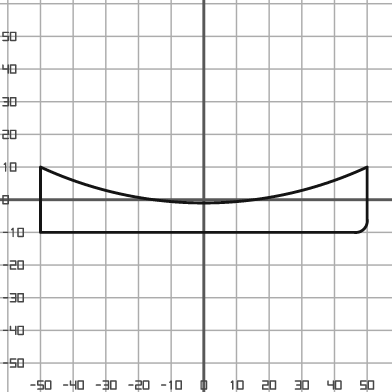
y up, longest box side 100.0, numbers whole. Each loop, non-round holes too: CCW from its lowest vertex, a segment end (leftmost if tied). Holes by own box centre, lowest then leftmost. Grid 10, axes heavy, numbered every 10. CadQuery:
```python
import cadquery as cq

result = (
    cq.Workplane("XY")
    .moveTo(-50.0, -10.0)
    .lineTo(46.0, -10.0)
    .threePointArc((49.0, -9.0), (50.0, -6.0))
    .lineTo(50.0, 10.0)
    .threePointArc((0.0, -1.0), (-50.0, 10.0))
    .close()
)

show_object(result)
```